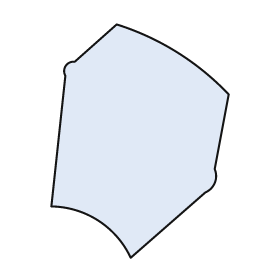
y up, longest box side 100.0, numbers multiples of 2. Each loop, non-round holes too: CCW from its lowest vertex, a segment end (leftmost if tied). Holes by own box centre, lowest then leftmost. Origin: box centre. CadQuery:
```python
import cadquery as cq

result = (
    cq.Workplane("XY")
    .moveTo(-4.0, -50.0)
    .lineTo(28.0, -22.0)
    .threePointArc((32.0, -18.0), (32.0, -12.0))
    .lineTo(38.0, 20.0)
    .threePointArc((16.0, 38.0), (-10.0, 50.0))
    .lineTo(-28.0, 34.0)
    .threePointArc((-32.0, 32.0), (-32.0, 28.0))
    .lineTo(-38.0, -28.0)
    .threePointArc((-18.0, -34.0), (-4.0, -50.0))
    .close()
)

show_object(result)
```